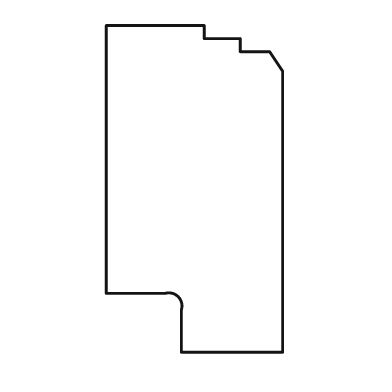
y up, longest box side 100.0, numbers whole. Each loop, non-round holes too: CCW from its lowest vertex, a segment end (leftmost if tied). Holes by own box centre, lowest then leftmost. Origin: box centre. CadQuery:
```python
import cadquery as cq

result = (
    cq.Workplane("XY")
    .moveTo(-4.0, -50.0)
    .lineTo(27.0, -50.0)
    .lineTo(27.0, 36.0)
    .lineTo(23.0, 42.0)
    .lineTo(14.0, 42.0)
    .lineTo(14.0, 46.0)
    .lineTo(3.0, 46.0)
    .lineTo(3.0, 50.0)
    .lineTo(-27.0, 50.0)
    .lineTo(-27.0, -32.0)
    .lineTo(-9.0, -32.0)
    .threePointArc((-5.0, -33.0), (-4.0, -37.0))
    .close()
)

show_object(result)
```